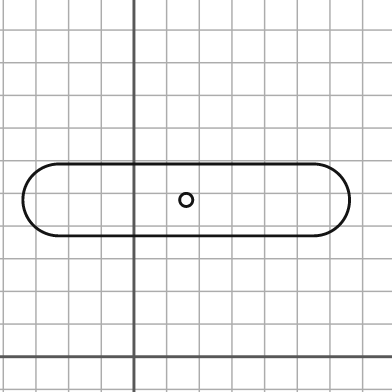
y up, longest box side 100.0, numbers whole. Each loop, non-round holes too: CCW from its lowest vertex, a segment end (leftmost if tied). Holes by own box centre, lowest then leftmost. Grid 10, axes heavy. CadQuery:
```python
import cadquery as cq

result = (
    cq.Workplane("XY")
    .moveTo(-23.0, 37.0)
    .lineTo(55.0, 37.0)
    .threePointArc((66.0, 48.0), (55.0, 59.0))
    .lineTo(-23.0, 59.0)
    .threePointArc((-34.0, 48.0), (-23.0, 37.0))
    .close()
    .moveTo(16.0, 48.0)
    .circle(2.0)
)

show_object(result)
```